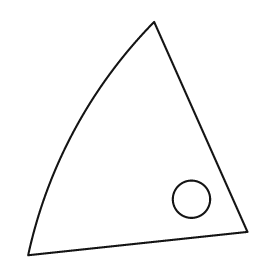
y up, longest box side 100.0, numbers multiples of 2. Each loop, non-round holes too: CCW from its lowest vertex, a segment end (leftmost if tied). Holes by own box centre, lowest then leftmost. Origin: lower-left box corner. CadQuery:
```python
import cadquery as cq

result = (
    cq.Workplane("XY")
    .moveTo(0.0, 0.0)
    .lineTo(94.0, 10.0)
    .lineTo(54.0, 100.0)
    .threePointArc((20.0, 54.0), (0.0, 0.0))
    .close()
    .moveTo(70.0, 24.0)
    .circle(8.0)
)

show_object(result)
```